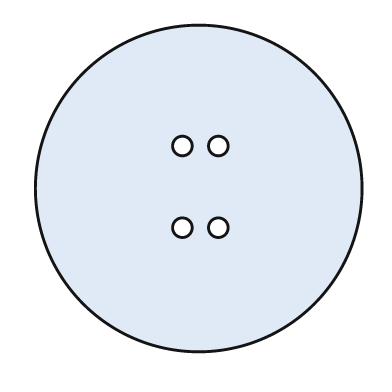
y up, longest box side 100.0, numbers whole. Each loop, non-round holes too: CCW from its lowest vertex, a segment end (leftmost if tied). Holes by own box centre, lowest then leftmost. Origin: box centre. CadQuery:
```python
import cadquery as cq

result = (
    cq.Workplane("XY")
    .moveTo(0.0, 0.0)
    .circle(50.0)
    .moveTo(-5.0, -12.0)
    .circle(3.0)
    .moveTo(6.0, -12.0)
    .circle(3.0)
    .moveTo(-5.0, 13.0)
    .circle(3.0)
    .moveTo(6.0, 13.0)
    .circle(3.0)
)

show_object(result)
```